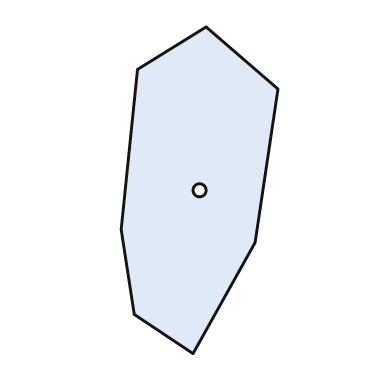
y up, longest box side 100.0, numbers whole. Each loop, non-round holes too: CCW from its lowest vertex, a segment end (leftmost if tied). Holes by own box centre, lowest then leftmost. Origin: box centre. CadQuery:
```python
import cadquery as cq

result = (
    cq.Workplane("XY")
    .moveTo(-2.0, -50.0)
    .lineTo(17.0, -16.0)
    .lineTo(24.0, 31.0)
    .lineTo(2.0, 50.0)
    .lineTo(-19.0, 37.0)
    .lineTo(-24.0, -12.0)
    .lineTo(-20.0, -38.0)
    .close()
    .moveTo(0.0, 0.0)
    .circle(2.0)
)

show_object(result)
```